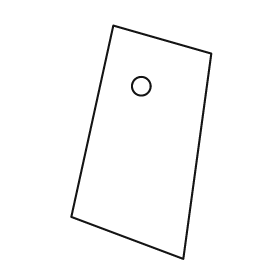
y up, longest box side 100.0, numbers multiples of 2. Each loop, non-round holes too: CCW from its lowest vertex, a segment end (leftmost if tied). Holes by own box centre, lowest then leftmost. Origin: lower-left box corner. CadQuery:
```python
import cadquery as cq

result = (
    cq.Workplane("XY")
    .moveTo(48.0, 0.0)
    .lineTo(60.0, 88.0)
    .lineTo(18.0, 100.0)
    .lineTo(0.0, 18.0)
    .close()
    .moveTo(30.0, 74.0)
    .circle(4.0)
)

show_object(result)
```